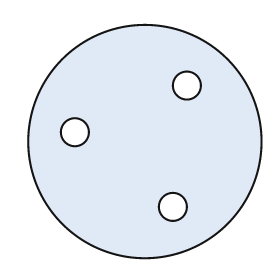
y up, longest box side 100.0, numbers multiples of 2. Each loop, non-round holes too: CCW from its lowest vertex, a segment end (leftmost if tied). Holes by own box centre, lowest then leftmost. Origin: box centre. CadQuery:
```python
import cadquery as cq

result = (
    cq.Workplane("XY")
    .moveTo(0.0, 0.0)
    .circle(50.0)
    .moveTo(12.0, -28.0)
    .circle(6.0)
    .moveTo(-30.0, 4.0)
    .circle(6.0)
    .moveTo(18.0, 24.0)
    .circle(6.0)
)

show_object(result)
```